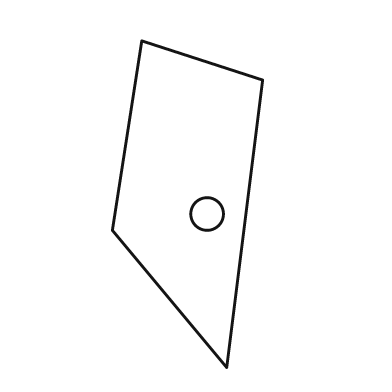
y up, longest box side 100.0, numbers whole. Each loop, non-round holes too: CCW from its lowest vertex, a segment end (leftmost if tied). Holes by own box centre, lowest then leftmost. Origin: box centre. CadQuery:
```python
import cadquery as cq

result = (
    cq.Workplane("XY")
    .moveTo(12.0, -50.0)
    .lineTo(23.0, 38.0)
    .lineTo(-14.0, 50.0)
    .lineTo(-23.0, -8.0)
    .close()
    .moveTo(6.0, -3.0)
    .circle(5.0)
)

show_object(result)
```